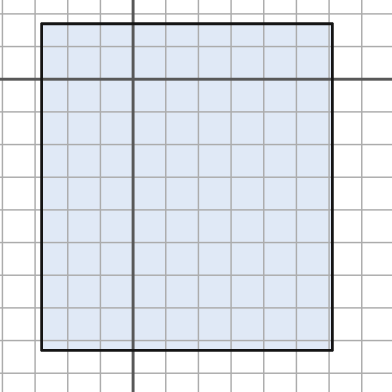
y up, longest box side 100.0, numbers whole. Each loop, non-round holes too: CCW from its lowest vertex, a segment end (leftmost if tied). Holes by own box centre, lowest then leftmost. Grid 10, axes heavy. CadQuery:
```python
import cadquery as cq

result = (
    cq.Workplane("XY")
    .moveTo(-28.0, -83.0)
    .lineTo(61.0, -83.0)
    .lineTo(61.0, 17.0)
    .lineTo(-28.0, 17.0)
    .close()
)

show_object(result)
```